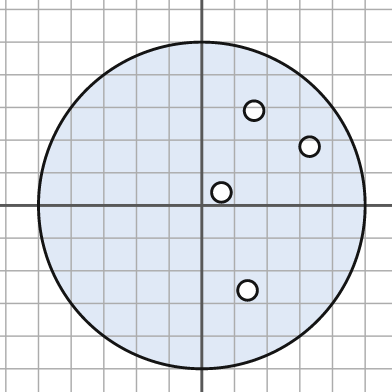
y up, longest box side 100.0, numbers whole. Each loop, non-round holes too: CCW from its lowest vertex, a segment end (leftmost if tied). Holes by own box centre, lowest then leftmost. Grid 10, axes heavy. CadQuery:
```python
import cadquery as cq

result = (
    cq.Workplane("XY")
    .moveTo(0.0, 0.0)
    .circle(50.0)
    .moveTo(14.0, -26.0)
    .circle(3.0)
    .moveTo(6.0, 4.0)
    .circle(3.0)
    .moveTo(33.0, 18.0)
    .circle(3.0)
    .moveTo(16.0, 29.0)
    .circle(3.0)
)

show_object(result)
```